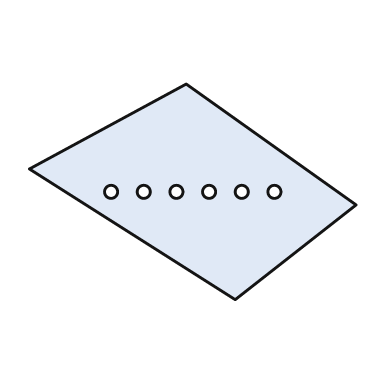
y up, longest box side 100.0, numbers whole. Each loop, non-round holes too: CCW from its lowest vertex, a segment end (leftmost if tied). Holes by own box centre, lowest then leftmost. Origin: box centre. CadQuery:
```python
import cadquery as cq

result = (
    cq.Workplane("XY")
    .moveTo(13.0, -33.0)
    .lineTo(50.0, -4.0)
    .lineTo(-2.0, 33.0)
    .lineTo(-50.0, 7.0)
    .close()
    .moveTo(-25.0, 0.0)
    .circle(2.0)
    .moveTo(-15.0, 0.0)
    .circle(2.0)
    .moveTo(-5.0, 0.0)
    .circle(2.0)
    .moveTo(5.0, 0.0)
    .circle(2.0)
    .moveTo(15.0, 0.0)
    .circle(2.0)
    .moveTo(25.0, 0.0)
    .circle(2.0)
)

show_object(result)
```